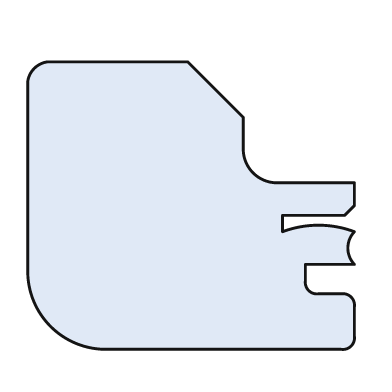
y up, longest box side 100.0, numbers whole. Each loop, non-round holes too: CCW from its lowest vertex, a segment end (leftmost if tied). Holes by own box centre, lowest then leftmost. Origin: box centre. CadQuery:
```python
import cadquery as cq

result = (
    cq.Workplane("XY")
    .moveTo(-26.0, -44.0)
    .lineTo(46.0, -44.0)
    .threePointArc((49.0, -43.0), (50.0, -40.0))
    .lineTo(50.0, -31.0)
    .threePointArc((49.0, -28.0), (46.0, -27.0))
    .lineTo(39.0, -27.0)
    .threePointArc((36.0, -26.0), (35.0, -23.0))
    .lineTo(35.0, -18.0)
    .lineTo(50.0, -18.0)
    .threePointArc((48.0, -13.0), (50.0, -8.0))
    .threePointArc((39.0, -6.0), (28.0, -8.0))
    .lineTo(28.0, -3.0)
    .lineTo(47.0, -3.0)
    .lineTo(50.0, 0.0)
    .lineTo(50.0, 7.0)
    .lineTo(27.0, 7.0)
    .threePointArc((19.0, 10.0), (16.0, 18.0))
    .lineTo(16.0, 27.0)
    .lineTo(-1.0, 44.0)
    .lineTo(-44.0, 44.0)
    .threePointArc((-48.0, 42.0), (-50.0, 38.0))
    .lineTo(-50.0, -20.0)
    .threePointArc((-43.0, -37.0), (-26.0, -44.0))
    .close()
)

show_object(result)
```